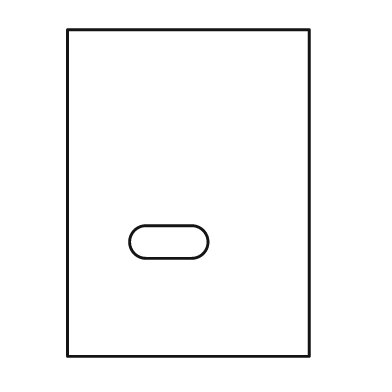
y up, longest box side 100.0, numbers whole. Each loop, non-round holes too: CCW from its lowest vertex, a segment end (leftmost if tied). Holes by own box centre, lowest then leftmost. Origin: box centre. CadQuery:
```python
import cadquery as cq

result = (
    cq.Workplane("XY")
    .moveTo(-37.0, -50.0)
    .lineTo(37.0, -50.0)
    .lineTo(37.0, 50.0)
    .lineTo(-37.0, 50.0)
    .close()
    .moveTo(-13.0, -20.0)
    .lineTo(1.0, -20.0)
    .threePointArc((6.0, -15.0), (1.0, -10.0))
    .lineTo(-13.0, -10.0)
    .threePointArc((-18.0, -15.0), (-13.0, -20.0))
    .close()
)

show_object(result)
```